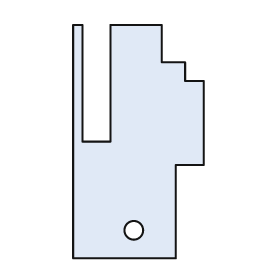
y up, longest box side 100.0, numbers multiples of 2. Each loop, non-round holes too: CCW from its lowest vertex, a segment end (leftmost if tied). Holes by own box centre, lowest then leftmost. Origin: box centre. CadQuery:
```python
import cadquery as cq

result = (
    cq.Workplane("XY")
    .moveTo(-28.0, -50.0)
    .lineTo(16.0, -50.0)
    .lineTo(16.0, -10.0)
    .lineTo(28.0, -10.0)
    .lineTo(28.0, 26.0)
    .lineTo(20.0, 26.0)
    .lineTo(20.0, 34.0)
    .lineTo(10.0, 34.0)
    .lineTo(10.0, 50.0)
    .lineTo(-12.0, 50.0)
    .lineTo(-12.0, 0.0)
    .lineTo(-24.0, 0.0)
    .lineTo(-24.0, 50.0)
    .lineTo(-28.0, 50.0)
    .close()
    .moveTo(-2.0, -38.0)
    .circle(4.0)
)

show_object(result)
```